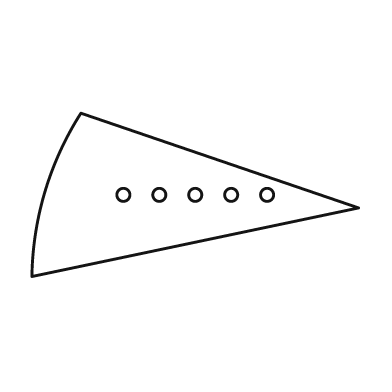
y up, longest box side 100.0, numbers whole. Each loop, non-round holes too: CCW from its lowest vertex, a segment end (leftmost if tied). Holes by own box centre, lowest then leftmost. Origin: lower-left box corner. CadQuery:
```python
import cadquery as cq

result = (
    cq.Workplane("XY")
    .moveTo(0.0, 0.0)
    .lineTo(100.0, 21.0)
    .lineTo(15.0, 50.0)
    .threePointArc((4.0, 26.0), (0.0, 0.0))
    .close()
    .moveTo(28.0, 25.0)
    .circle(2.0)
    .moveTo(39.0, 25.0)
    .circle(2.0)
    .moveTo(50.0, 25.0)
    .circle(2.0)
    .moveTo(61.0, 25.0)
    .circle(2.0)
    .moveTo(72.0, 25.0)
    .circle(2.0)
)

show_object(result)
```